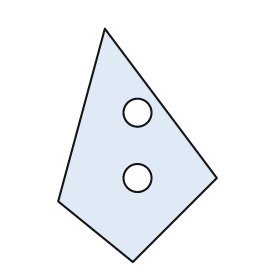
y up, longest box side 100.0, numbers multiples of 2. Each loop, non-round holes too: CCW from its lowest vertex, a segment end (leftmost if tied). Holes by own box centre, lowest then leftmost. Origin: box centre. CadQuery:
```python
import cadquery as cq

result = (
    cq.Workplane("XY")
    .moveTo(-2.0, -50.0)
    .lineTo(34.0, -14.0)
    .lineTo(-14.0, 50.0)
    .lineTo(-34.0, -24.0)
    .close()
    .moveTo(0.0, -14.0)
    .circle(6.0)
    .moveTo(0.0, 14.0)
    .circle(6.0)
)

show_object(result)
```